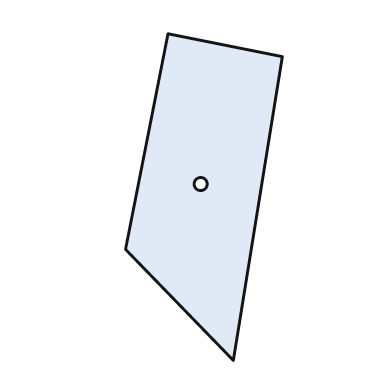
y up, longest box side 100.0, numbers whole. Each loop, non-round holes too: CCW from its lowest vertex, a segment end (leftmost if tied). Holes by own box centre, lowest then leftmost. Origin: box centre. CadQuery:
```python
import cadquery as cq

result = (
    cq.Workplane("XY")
    .moveTo(9.0, -50.0)
    .lineTo(24.0, 43.0)
    .lineTo(-11.0, 50.0)
    .lineTo(-24.0, -16.0)
    .close()
    .moveTo(-1.0, 4.0)
    .circle(2.0)
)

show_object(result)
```